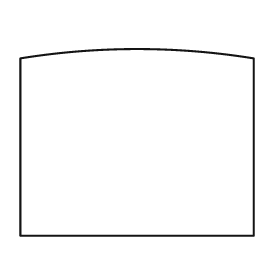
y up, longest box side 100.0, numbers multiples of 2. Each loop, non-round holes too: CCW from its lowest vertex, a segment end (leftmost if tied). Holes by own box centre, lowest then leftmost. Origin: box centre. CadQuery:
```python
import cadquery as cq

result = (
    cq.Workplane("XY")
    .moveTo(-50.0, -40.0)
    .lineTo(50.0, -40.0)
    .lineTo(50.0, 36.0)
    .threePointArc((0.0, 40.0), (-50.0, 36.0))
    .close()
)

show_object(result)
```